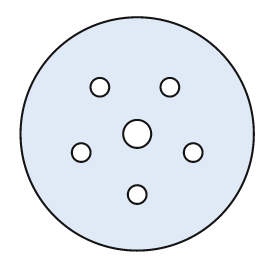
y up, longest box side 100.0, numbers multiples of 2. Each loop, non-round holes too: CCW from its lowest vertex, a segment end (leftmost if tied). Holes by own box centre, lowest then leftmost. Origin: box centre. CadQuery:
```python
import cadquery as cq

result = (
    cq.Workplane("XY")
    .moveTo(0.0, 0.0)
    .circle(50.0)
    .moveTo(0.0, -26.0)
    .circle(4.0)
    .moveTo(-24.0, -8.0)
    .circle(4.0)
    .moveTo(24.0, -8.0)
    .circle(4.0)
    .moveTo(0.0, 0.0)
    .circle(6.0)
    .moveTo(-16.0, 20.0)
    .circle(4.0)
    .moveTo(14.0, 20.0)
    .circle(4.0)
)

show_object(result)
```